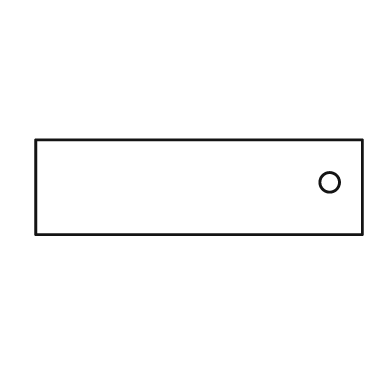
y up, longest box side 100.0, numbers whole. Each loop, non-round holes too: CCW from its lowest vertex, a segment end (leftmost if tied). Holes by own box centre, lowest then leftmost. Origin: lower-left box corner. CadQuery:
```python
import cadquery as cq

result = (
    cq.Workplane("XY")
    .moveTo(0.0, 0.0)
    .lineTo(100.0, 0.0)
    .lineTo(100.0, 29.0)
    .lineTo(0.0, 29.0)
    .close()
    .moveTo(90.0, 16.0)
    .circle(3.0)
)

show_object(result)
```